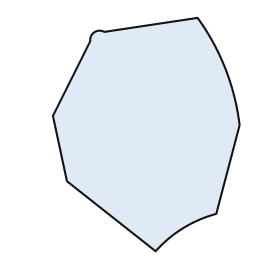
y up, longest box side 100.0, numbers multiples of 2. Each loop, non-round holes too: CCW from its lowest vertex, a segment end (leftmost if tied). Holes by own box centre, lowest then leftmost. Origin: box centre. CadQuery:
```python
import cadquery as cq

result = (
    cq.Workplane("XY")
    .moveTo(4.0, -50.0)
    .threePointArc((16.0, -40.0), (30.0, -34.0))
    .lineTo(40.0, 4.0)
    .threePointArc((34.0, 28.0), (22.0, 50.0))
    .lineTo(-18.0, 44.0)
    .threePointArc((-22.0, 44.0), (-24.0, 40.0))
    .lineTo(-40.0, 8.0)
    .lineTo(-34.0, -20.0)
    .close()
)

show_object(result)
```